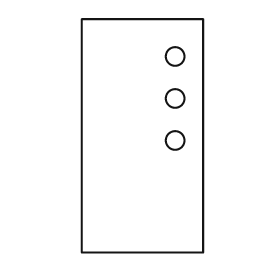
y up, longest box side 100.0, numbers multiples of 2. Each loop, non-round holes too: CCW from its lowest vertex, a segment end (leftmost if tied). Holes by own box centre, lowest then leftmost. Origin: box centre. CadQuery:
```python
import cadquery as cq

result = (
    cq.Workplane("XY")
    .moveTo(-26.0, -50.0)
    .lineTo(26.0, -50.0)
    .lineTo(26.0, 50.0)
    .lineTo(-26.0, 50.0)
    .close()
    .moveTo(14.0, -2.0)
    .circle(4.0)
    .moveTo(14.0, 16.0)
    .circle(4.0)
    .moveTo(14.0, 34.0)
    .circle(4.0)
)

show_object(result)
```